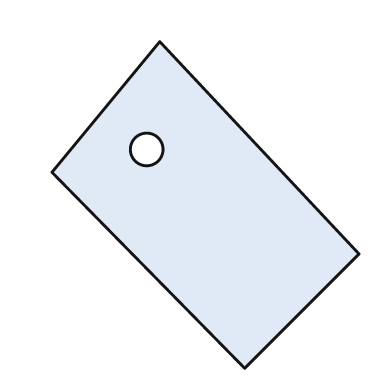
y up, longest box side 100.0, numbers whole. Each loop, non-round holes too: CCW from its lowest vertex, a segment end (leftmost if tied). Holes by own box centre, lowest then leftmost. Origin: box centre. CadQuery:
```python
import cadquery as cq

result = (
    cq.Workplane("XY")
    .moveTo(12.0, -50.0)
    .lineTo(47.0, -15.0)
    .lineTo(-14.0, 50.0)
    .lineTo(-47.0, 10.0)
    .close()
    .moveTo(-18.0, 17.0)
    .circle(5.0)
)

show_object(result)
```